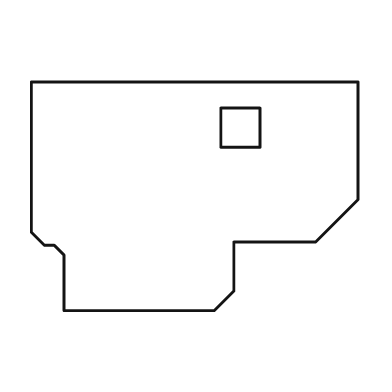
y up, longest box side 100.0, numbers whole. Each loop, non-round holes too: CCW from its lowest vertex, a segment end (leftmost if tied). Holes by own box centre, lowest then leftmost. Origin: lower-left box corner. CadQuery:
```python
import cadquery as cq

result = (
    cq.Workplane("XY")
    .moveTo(10.0, 0.0)
    .lineTo(56.0, 0.0)
    .lineTo(62.0, 6.0)
    .lineTo(62.0, 21.0)
    .lineTo(87.0, 21.0)
    .lineTo(100.0, 34.0)
    .lineTo(100.0, 70.0)
    .lineTo(0.0, 70.0)
    .lineTo(0.0, 24.0)
    .lineTo(4.0, 20.0)
    .lineTo(7.0, 20.0)
    .lineTo(10.0, 17.0)
    .close()
    .moveTo(58.0, 50.0)
    .lineTo(70.0, 50.0)
    .lineTo(70.0, 62.0)
    .lineTo(58.0, 62.0)
    .close()
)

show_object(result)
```